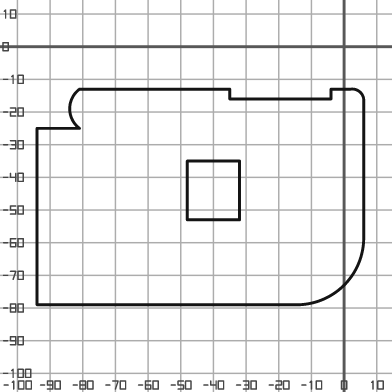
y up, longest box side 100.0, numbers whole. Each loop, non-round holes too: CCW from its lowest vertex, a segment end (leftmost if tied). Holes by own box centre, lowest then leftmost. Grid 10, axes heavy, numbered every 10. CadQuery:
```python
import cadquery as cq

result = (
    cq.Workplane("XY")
    .moveTo(-94.0, -79.0)
    .lineTo(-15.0, -79.0)
    .threePointArc((0.0, -73.0), (6.0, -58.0))
    .lineTo(6.0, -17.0)
    .threePointArc((5.0, -14.0), (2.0, -13.0))
    .lineTo(-4.0, -13.0)
    .lineTo(-4.0, -16.0)
    .lineTo(-35.0, -16.0)
    .lineTo(-35.0, -13.0)
    .lineTo(-81.0, -13.0)
    .threePointArc((-84.0, -19.0), (-81.0, -25.0))
    .lineTo(-94.0, -25.0)
    .close()
    .moveTo(-48.0, -53.0)
    .lineTo(-32.0, -53.0)
    .lineTo(-32.0, -35.0)
    .lineTo(-48.0, -35.0)
    .close()
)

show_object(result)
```